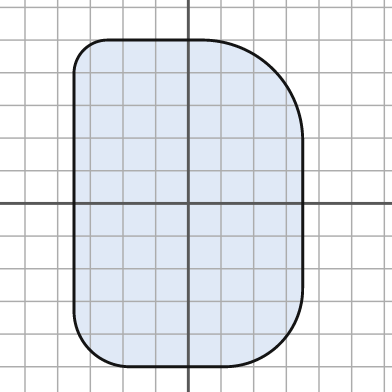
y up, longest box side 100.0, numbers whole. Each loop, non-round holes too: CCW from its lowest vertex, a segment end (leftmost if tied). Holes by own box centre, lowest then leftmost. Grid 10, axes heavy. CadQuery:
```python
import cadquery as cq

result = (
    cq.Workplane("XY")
    .moveTo(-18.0, -50.0)
    .lineTo(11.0, -50.0)
    .threePointArc((28.0, -43.0), (35.0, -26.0))
    .lineTo(35.0, 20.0)
    .threePointArc((26.0, 41.0), (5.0, 50.0))
    .lineTo(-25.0, 50.0)
    .threePointArc((-32.0, 47.0), (-35.0, 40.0))
    .lineTo(-35.0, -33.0)
    .threePointArc((-30.0, -45.0), (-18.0, -50.0))
    .close()
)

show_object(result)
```